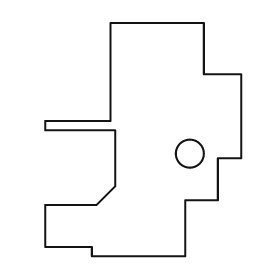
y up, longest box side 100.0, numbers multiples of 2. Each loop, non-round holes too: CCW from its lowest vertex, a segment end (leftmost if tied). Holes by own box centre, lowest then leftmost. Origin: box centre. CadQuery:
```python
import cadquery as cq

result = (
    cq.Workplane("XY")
    .moveTo(-22.0, -50.0)
    .lineTo(18.0, -50.0)
    .lineTo(18.0, -26.0)
    .lineTo(32.0, -26.0)
    .lineTo(32.0, -8.0)
    .lineTo(42.0, -8.0)
    .lineTo(42.0, 28.0)
    .lineTo(26.0, 28.0)
    .lineTo(26.0, 50.0)
    .lineTo(-14.0, 50.0)
    .lineTo(-14.0, 8.0)
    .lineTo(-42.0, 8.0)
    .lineTo(-42.0, 4.0)
    .lineTo(-12.0, 4.0)
    .lineTo(-12.0, -20.0)
    .lineTo(-20.0, -28.0)
    .lineTo(-42.0, -28.0)
    .lineTo(-42.0, -46.0)
    .lineTo(-22.0, -46.0)
    .close()
    .moveTo(20.0, -6.0)
    .circle(6.0)
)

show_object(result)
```